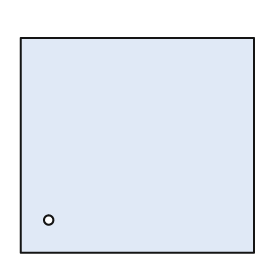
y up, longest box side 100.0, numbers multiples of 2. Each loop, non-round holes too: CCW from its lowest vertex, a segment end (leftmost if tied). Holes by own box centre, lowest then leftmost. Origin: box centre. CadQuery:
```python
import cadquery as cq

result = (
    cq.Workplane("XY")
    .moveTo(-50.0, -46.0)
    .lineTo(50.0, -46.0)
    .lineTo(50.0, 46.0)
    .lineTo(-50.0, 46.0)
    .close()
    .moveTo(-38.0, -32.0)
    .circle(2.0)
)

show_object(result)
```